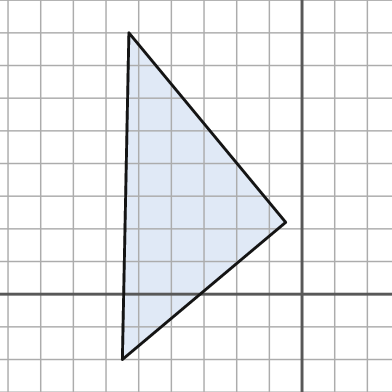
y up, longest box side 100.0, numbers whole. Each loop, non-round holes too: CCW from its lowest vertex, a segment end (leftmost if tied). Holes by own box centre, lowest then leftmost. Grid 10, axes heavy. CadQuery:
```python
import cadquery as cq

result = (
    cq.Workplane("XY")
    .moveTo(-55.0, -20.0)
    .lineTo(-5.0, 22.0)
    .lineTo(-53.0, 80.0)
    .close()
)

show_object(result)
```